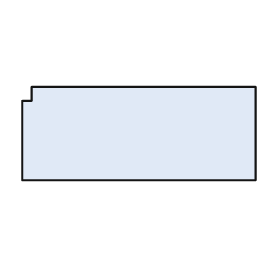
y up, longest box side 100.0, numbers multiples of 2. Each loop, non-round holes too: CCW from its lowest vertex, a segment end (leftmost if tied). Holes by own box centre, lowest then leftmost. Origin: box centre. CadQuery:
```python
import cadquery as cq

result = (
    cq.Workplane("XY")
    .moveTo(-50.0, -20.0)
    .lineTo(50.0, -20.0)
    .lineTo(50.0, 20.0)
    .lineTo(-46.0, 20.0)
    .lineTo(-46.0, 14.0)
    .lineTo(-50.0, 14.0)
    .close()
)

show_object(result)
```